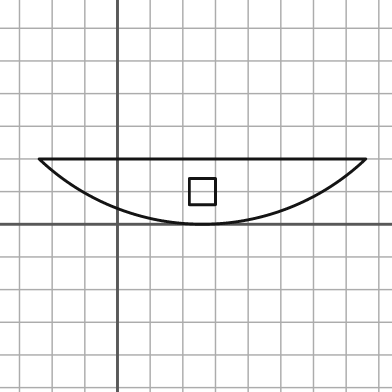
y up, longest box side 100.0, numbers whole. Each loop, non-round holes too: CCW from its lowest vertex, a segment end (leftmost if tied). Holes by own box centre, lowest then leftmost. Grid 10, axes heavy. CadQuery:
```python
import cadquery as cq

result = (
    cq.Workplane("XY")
    .moveTo(-24.0, 20.0)
    .threePointArc((26.0, 0.0), (76.0, 20.0))
    .close()
    .moveTo(22.0, 6.0)
    .lineTo(30.0, 6.0)
    .lineTo(30.0, 14.0)
    .lineTo(22.0, 14.0)
    .close()
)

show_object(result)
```